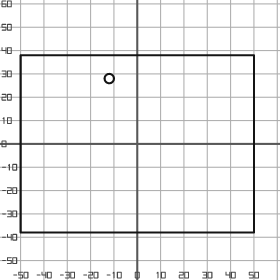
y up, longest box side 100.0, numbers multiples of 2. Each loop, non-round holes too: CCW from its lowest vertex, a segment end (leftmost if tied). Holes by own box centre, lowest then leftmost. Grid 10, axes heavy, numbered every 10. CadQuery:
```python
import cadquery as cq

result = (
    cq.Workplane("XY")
    .moveTo(-50.0, -38.0)
    .lineTo(50.0, -38.0)
    .lineTo(50.0, 38.0)
    .lineTo(-50.0, 38.0)
    .close()
    .moveTo(-12.0, 28.0)
    .circle(2.0)
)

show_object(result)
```